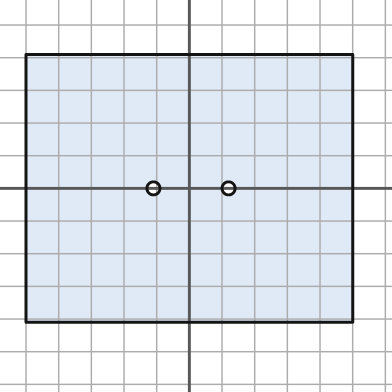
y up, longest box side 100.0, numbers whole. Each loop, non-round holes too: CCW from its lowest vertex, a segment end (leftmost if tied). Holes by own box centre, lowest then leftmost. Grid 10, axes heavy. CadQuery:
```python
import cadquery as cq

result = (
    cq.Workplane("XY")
    .moveTo(-50.0, -41.0)
    .lineTo(50.0, -41.0)
    .lineTo(50.0, 41.0)
    .lineTo(-50.0, 41.0)
    .close()
    .moveTo(-11.0, 0.0)
    .circle(2.0)
    .moveTo(12.0, 0.0)
    .circle(2.0)
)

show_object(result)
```